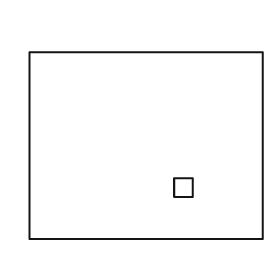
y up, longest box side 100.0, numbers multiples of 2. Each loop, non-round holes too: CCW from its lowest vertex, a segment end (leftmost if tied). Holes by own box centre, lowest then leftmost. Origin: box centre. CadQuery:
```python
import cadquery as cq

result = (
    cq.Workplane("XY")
    .moveTo(-50.0, -40.0)
    .lineTo(50.0, -40.0)
    .lineTo(50.0, 40.0)
    .lineTo(-50.0, 40.0)
    .close()
    .moveTo(12.0, -22.0)
    .lineTo(20.0, -22.0)
    .lineTo(20.0, -14.0)
    .lineTo(12.0, -14.0)
    .close()
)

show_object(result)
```